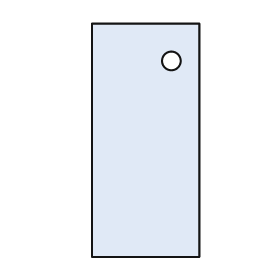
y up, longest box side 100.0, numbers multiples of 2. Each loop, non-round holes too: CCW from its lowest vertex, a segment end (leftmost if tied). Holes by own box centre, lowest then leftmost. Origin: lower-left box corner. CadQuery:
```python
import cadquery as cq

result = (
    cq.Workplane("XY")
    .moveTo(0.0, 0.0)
    .lineTo(46.0, 0.0)
    .lineTo(46.0, 100.0)
    .lineTo(0.0, 100.0)
    .close()
    .moveTo(34.0, 84.0)
    .circle(4.0)
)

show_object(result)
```